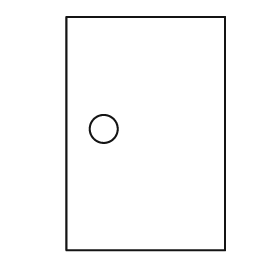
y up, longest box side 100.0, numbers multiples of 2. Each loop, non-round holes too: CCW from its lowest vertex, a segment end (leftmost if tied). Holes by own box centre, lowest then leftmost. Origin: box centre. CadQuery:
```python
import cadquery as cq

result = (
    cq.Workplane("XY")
    .moveTo(-34.0, -50.0)
    .lineTo(34.0, -50.0)
    .lineTo(34.0, 50.0)
    .lineTo(-34.0, 50.0)
    .close()
    .moveTo(-18.0, 2.0)
    .circle(6.0)
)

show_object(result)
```